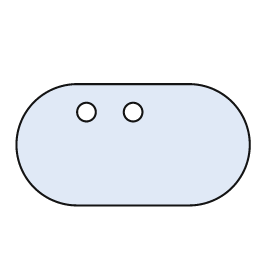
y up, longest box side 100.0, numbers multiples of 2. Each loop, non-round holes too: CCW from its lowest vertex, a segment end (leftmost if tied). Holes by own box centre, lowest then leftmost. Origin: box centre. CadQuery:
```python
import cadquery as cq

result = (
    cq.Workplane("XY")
    .moveTo(-24.0, -26.0)
    .lineTo(24.0, -26.0)
    .threePointArc((50.0, 0.0), (24.0, 26.0))
    .lineTo(-24.0, 26.0)
    .threePointArc((-50.0, 0.0), (-24.0, -26.0))
    .close()
    .moveTo(-20.0, 14.0)
    .circle(4.0)
    .moveTo(0.0, 14.0)
    .circle(4.0)
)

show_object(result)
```